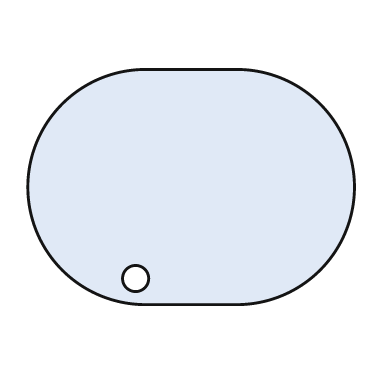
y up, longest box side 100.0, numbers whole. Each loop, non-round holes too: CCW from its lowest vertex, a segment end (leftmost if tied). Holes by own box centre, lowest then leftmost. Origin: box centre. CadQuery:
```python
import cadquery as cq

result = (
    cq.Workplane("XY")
    .moveTo(-14.0, -36.0)
    .lineTo(14.0, -36.0)
    .threePointArc((50.0, 0.0), (14.0, 36.0))
    .lineTo(-14.0, 36.0)
    .threePointArc((-50.0, 0.0), (-14.0, -36.0))
    .close()
    .moveTo(-17.0, -28.0)
    .circle(4.0)
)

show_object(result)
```